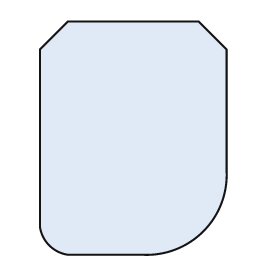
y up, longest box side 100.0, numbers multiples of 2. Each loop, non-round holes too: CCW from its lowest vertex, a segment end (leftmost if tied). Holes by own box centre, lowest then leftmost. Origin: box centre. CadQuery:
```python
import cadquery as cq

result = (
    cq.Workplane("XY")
    .moveTo(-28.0, -50.0)
    .lineTo(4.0, -50.0)
    .threePointArc((30.0, -40.0), (40.0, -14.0))
    .lineTo(40.0, 38.0)
    .lineTo(28.0, 50.0)
    .lineTo(-28.0, 50.0)
    .lineTo(-40.0, 38.0)
    .lineTo(-40.0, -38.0)
    .threePointArc((-36.0, -46.0), (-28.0, -50.0))
    .close()
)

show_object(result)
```